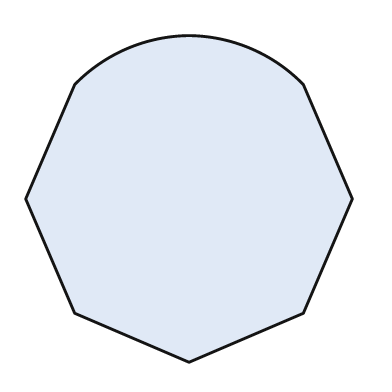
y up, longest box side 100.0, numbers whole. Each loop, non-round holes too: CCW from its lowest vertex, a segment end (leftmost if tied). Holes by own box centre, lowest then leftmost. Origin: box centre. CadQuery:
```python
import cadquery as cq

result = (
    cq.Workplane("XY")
    .moveTo(0.0, -50.0)
    .lineTo(35.0, -35.0)
    .lineTo(50.0, 0.0)
    .lineTo(35.0, 35.0)
    .threePointArc((19.0, 46.0), (0.0, 50.0))
    .threePointArc((-19.0, 46.0), (-35.0, 35.0))
    .lineTo(-50.0, 0.0)
    .lineTo(-35.0, -35.0)
    .close()
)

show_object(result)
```